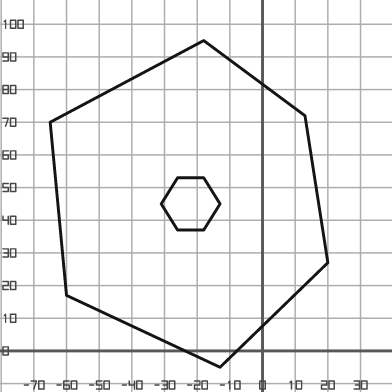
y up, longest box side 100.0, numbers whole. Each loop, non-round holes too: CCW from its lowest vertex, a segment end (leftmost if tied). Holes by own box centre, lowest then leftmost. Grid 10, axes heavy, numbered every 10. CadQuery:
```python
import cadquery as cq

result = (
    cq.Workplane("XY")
    .moveTo(-13.0, -5.0)
    .lineTo(20.0, 27.0)
    .lineTo(13.0, 72.0)
    .lineTo(-18.0, 95.0)
    .lineTo(-65.0, 70.0)
    .lineTo(-60.0, 17.0)
    .close()
    .moveTo(-26.0, 37.0)
    .lineTo(-18.0, 37.0)
    .lineTo(-13.0, 45.0)
    .lineTo(-18.0, 53.0)
    .lineTo(-26.0, 53.0)
    .lineTo(-31.0, 45.0)
    .close()
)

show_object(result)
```